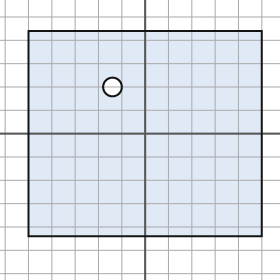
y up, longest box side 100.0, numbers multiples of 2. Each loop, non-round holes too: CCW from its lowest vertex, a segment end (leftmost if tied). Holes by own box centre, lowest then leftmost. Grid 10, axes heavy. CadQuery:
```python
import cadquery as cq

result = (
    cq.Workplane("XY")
    .moveTo(-50.0, -44.0)
    .lineTo(50.0, -44.0)
    .lineTo(50.0, 44.0)
    .lineTo(-50.0, 44.0)
    .close()
    .moveTo(-14.0, 20.0)
    .circle(4.0)
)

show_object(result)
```